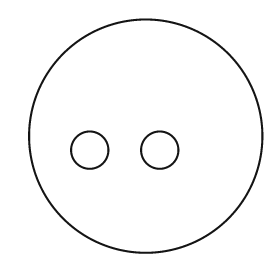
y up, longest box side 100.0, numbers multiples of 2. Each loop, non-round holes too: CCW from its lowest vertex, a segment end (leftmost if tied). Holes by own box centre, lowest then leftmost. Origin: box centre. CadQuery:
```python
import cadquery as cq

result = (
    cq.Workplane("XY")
    .moveTo(0.0, 0.0)
    .circle(50.0)
    .moveTo(-24.0, -6.0)
    .circle(8.0)
    .moveTo(6.0, -6.0)
    .circle(8.0)
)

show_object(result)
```